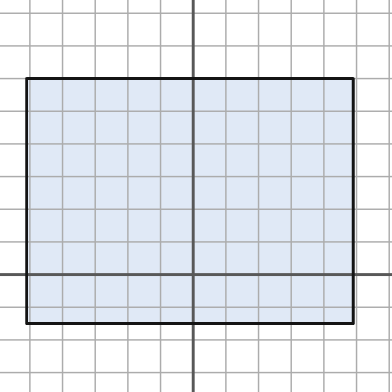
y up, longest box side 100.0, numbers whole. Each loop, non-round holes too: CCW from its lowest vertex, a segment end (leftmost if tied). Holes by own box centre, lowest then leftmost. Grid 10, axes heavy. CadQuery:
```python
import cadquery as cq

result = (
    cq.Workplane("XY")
    .moveTo(-51.0, -15.0)
    .lineTo(49.0, -15.0)
    .lineTo(49.0, 60.0)
    .lineTo(-51.0, 60.0)
    .close()
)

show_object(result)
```